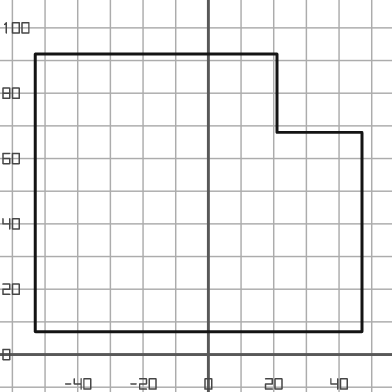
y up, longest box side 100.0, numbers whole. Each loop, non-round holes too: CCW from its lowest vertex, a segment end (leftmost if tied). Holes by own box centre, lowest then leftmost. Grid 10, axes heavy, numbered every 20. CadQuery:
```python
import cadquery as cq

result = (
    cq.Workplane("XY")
    .moveTo(-53.0, 7.0)
    .lineTo(47.0, 7.0)
    .lineTo(47.0, 68.0)
    .lineTo(21.0, 68.0)
    .lineTo(21.0, 92.0)
    .lineTo(-53.0, 92.0)
    .close()
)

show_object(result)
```